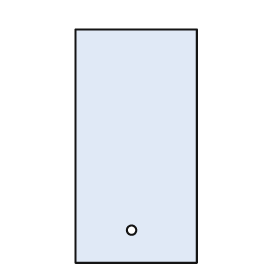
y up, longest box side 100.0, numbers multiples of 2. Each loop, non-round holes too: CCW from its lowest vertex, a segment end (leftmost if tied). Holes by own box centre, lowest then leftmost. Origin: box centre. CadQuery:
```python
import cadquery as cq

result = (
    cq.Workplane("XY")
    .moveTo(-26.0, -50.0)
    .lineTo(26.0, -50.0)
    .lineTo(26.0, 50.0)
    .lineTo(-26.0, 50.0)
    .close()
    .moveTo(-2.0, -36.0)
    .circle(2.0)
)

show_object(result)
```